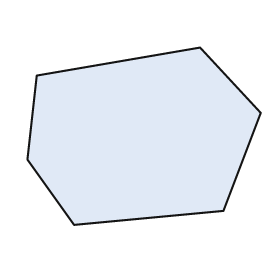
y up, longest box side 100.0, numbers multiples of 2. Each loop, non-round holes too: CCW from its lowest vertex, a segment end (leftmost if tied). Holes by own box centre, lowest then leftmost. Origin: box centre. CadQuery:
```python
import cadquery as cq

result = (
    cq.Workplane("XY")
    .moveTo(-30.0, -38.0)
    .lineTo(34.0, -32.0)
    .lineTo(50.0, 10.0)
    .lineTo(24.0, 38.0)
    .lineTo(-46.0, 26.0)
    .lineTo(-50.0, -10.0)
    .close()
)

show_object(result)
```